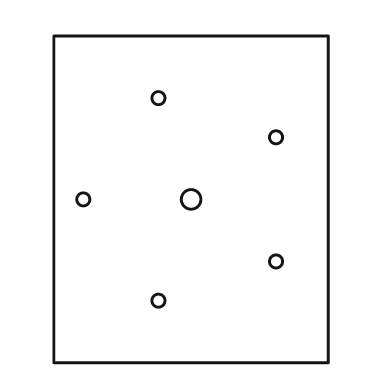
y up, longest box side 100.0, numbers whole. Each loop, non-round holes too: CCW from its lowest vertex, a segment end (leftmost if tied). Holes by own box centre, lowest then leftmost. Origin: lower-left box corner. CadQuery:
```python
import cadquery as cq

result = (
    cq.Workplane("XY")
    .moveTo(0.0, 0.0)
    .lineTo(84.0, 0.0)
    .lineTo(84.0, 100.0)
    .lineTo(0.0, 100.0)
    .close()
    .moveTo(32.0, 19.0)
    .circle(2.0)
    .moveTo(68.0, 31.0)
    .circle(2.0)
    .moveTo(9.0, 50.0)
    .circle(2.0)
    .moveTo(42.0, 50.0)
    .circle(3.0)
    .moveTo(68.0, 69.0)
    .circle(2.0)
    .moveTo(32.0, 81.0)
    .circle(2.0)
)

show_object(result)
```